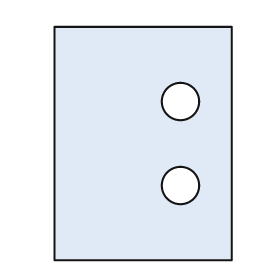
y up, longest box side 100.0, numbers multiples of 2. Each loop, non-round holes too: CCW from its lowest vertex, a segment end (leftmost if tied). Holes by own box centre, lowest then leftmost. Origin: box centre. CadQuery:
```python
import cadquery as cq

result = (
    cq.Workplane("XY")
    .moveTo(-38.0, -50.0)
    .lineTo(38.0, -50.0)
    .lineTo(38.0, 50.0)
    .lineTo(-38.0, 50.0)
    .close()
    .moveTo(16.0, -18.0)
    .circle(8.0)
    .moveTo(16.0, 18.0)
    .circle(8.0)
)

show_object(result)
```